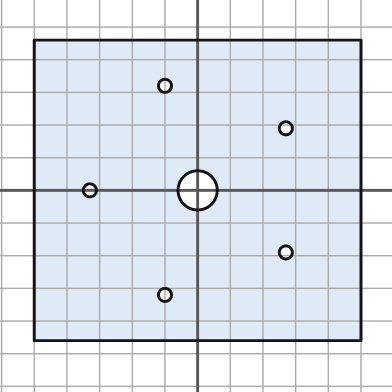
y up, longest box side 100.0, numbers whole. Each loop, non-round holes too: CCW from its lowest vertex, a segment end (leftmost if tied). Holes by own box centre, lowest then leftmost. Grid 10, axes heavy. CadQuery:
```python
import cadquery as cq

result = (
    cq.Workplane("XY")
    .moveTo(-50.0, -46.0)
    .lineTo(50.0, -46.0)
    .lineTo(50.0, 46.0)
    .lineTo(-50.0, 46.0)
    .close()
    .moveTo(-10.0, -32.0)
    .circle(2.0)
    .moveTo(27.0, -19.0)
    .circle(2.0)
    .moveTo(-33.0, 0.0)
    .circle(2.0)
    .moveTo(0.0, 0.0)
    .circle(6.0)
    .moveTo(27.0, 19.0)
    .circle(2.0)
    .moveTo(-10.0, 32.0)
    .circle(2.0)
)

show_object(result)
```